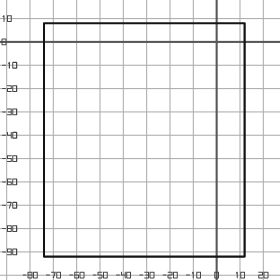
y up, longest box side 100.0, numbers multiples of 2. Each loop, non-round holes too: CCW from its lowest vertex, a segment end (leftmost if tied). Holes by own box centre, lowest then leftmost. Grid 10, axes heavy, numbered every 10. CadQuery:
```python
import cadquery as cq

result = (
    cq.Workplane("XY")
    .moveTo(-74.0, -92.0)
    .lineTo(12.0, -92.0)
    .lineTo(12.0, 8.0)
    .lineTo(-74.0, 8.0)
    .close()
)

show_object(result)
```